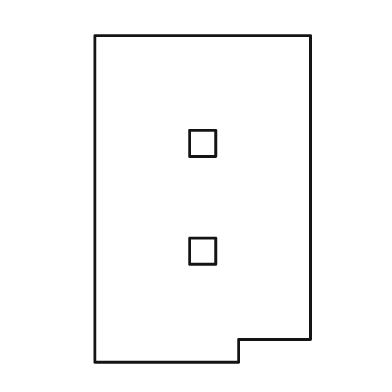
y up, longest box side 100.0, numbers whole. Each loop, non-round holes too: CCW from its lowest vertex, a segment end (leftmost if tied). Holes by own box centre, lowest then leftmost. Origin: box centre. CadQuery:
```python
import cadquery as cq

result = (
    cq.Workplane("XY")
    .moveTo(-33.0, -50.0)
    .lineTo(11.0, -50.0)
    .lineTo(11.0, -43.0)
    .lineTo(33.0, -43.0)
    .lineTo(33.0, 50.0)
    .lineTo(-33.0, 50.0)
    .close()
    .moveTo(-4.0, -20.0)
    .lineTo(4.0, -20.0)
    .lineTo(4.0, -12.0)
    .lineTo(-4.0, -12.0)
    .close()
    .moveTo(-4.0, 13.0)
    .lineTo(4.0, 13.0)
    .lineTo(4.0, 21.0)
    .lineTo(-4.0, 21.0)
    .close()
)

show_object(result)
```